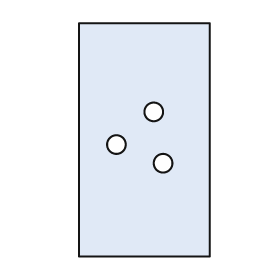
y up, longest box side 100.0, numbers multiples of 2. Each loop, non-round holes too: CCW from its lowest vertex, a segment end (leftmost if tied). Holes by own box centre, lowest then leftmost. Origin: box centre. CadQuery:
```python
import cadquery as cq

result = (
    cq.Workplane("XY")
    .moveTo(-28.0, -50.0)
    .lineTo(28.0, -50.0)
    .lineTo(28.0, 50.0)
    .lineTo(-28.0, 50.0)
    .close()
    .moveTo(8.0, -10.0)
    .circle(4.0)
    .moveTo(-12.0, -2.0)
    .circle(4.0)
    .moveTo(4.0, 12.0)
    .circle(4.0)
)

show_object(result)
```